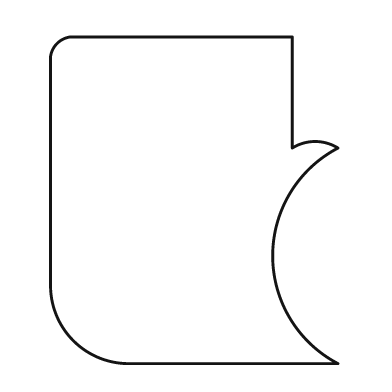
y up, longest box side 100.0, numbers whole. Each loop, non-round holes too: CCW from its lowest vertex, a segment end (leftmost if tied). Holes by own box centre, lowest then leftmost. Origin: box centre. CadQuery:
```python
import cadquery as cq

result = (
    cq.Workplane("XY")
    .moveTo(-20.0, -50.0)
    .lineTo(44.0, -50.0)
    .threePointArc((24.0, -17.0), (44.0, 16.0))
    .threePointArc((37.0, 18.0), (30.0, 16.0))
    .lineTo(30.0, 50.0)
    .lineTo(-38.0, 50.0)
    .threePointArc((-42.0, 48.0), (-44.0, 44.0))
    .lineTo(-44.0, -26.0)
    .threePointArc((-37.0, -43.0), (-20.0, -50.0))
    .close()
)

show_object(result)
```